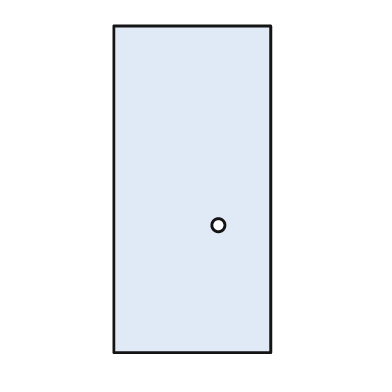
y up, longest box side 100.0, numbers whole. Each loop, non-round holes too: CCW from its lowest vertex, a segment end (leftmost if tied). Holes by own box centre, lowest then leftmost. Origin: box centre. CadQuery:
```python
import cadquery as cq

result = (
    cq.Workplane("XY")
    .moveTo(-24.0, -50.0)
    .lineTo(24.0, -50.0)
    .lineTo(24.0, 50.0)
    .lineTo(-24.0, 50.0)
    .close()
    .moveTo(8.0, -11.0)
    .circle(2.0)
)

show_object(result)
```